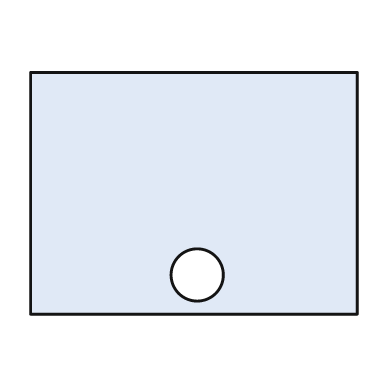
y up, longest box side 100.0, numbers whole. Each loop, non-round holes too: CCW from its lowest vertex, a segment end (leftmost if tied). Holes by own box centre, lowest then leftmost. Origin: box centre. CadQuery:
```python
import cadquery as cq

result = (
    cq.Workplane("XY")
    .moveTo(-50.0, -37.0)
    .lineTo(50.0, -37.0)
    .lineTo(50.0, 37.0)
    .lineTo(-50.0, 37.0)
    .close()
    .moveTo(1.0, -25.0)
    .circle(8.0)
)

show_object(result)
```